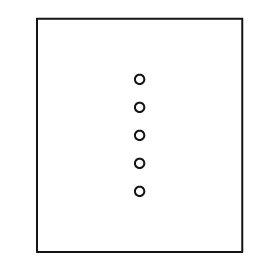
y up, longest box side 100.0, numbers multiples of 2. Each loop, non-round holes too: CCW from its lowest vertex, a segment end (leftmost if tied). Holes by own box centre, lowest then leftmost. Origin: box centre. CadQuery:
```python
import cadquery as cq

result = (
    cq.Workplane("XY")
    .moveTo(-44.0, -50.0)
    .lineTo(44.0, -50.0)
    .lineTo(44.0, 50.0)
    .lineTo(-44.0, 50.0)
    .close()
    .moveTo(0.0, -24.0)
    .circle(2.0)
    .moveTo(0.0, -12.0)
    .circle(2.0)
    .moveTo(0.0, 0.0)
    .circle(2.0)
    .moveTo(0.0, 12.0)
    .circle(2.0)
    .moveTo(0.0, 24.0)
    .circle(2.0)
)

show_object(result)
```